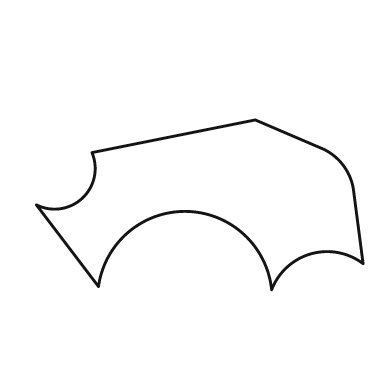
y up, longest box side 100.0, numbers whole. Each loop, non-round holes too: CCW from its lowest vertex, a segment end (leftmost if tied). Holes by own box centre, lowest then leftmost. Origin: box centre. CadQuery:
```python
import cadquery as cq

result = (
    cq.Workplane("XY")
    .moveTo(22.0, -26.0)
    .threePointArc((34.0, -15.0), (50.0, -18.0))
    .lineTo(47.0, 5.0)
    .threePointArc((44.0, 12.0), (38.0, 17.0))
    .lineTo(17.0, 26.0)
    .lineTo(-33.0, 16.0)
    .threePointArc((-36.0, 2.0), (-50.0, 0.0))
    .lineTo(-31.0, -25.0)
    .threePointArc((-4.0, -2.0), (22.0, -26.0))
    .close()
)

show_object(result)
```